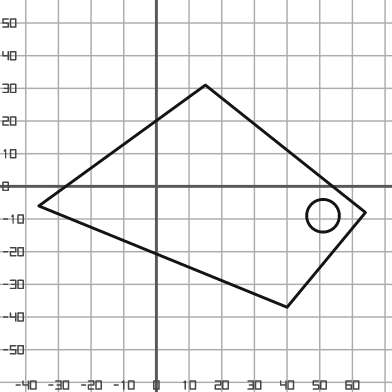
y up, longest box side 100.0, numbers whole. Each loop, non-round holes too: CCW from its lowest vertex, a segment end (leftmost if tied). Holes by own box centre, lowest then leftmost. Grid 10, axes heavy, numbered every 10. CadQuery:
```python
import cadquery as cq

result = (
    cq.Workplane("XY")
    .moveTo(40.0, -37.0)
    .lineTo(64.0, -8.0)
    .lineTo(15.0, 31.0)
    .lineTo(-36.0, -6.0)
    .close()
    .moveTo(51.0, -9.0)
    .circle(5.0)
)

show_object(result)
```